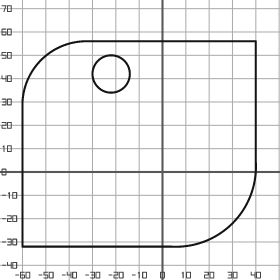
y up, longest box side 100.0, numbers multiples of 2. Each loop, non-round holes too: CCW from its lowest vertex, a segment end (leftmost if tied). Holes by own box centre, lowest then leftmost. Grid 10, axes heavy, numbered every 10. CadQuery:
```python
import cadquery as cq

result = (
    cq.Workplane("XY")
    .moveTo(-60.0, -32.0)
    .lineTo(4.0, -32.0)
    .threePointArc((30.0, -22.0), (40.0, 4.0))
    .lineTo(40.0, 56.0)
    .lineTo(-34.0, 56.0)
    .threePointArc((-52.0, 48.0), (-60.0, 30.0))
    .close()
    .moveTo(-22.0, 42.0)
    .circle(8.0)
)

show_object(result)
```